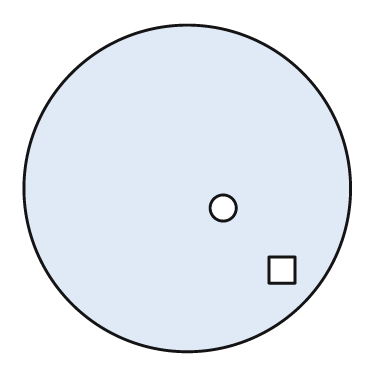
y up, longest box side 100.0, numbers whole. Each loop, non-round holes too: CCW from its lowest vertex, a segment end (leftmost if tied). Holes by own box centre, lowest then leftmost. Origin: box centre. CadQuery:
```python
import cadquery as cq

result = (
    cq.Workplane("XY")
    .moveTo(0.0, 0.0)
    .circle(50.0)
    .moveTo(25.0, -29.0)
    .lineTo(33.0, -29.0)
    .lineTo(33.0, -21.0)
    .lineTo(25.0, -21.0)
    .close()
    .moveTo(11.0, -6.0)
    .circle(4.0)
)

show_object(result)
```